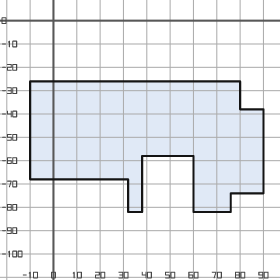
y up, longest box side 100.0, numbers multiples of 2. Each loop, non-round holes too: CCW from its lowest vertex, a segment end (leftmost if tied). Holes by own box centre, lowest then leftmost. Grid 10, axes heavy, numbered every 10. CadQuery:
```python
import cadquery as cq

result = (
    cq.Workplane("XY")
    .moveTo(32.0, -82.0)
    .lineTo(38.0, -82.0)
    .lineTo(38.0, -58.0)
    .lineTo(60.0, -58.0)
    .lineTo(60.0, -82.0)
    .lineTo(76.0, -82.0)
    .lineTo(76.0, -74.0)
    .lineTo(90.0, -74.0)
    .lineTo(90.0, -38.0)
    .lineTo(80.0, -38.0)
    .lineTo(80.0, -26.0)
    .lineTo(-10.0, -26.0)
    .lineTo(-10.0, -68.0)
    .lineTo(32.0, -68.0)
    .close()
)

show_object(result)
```